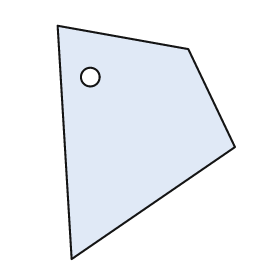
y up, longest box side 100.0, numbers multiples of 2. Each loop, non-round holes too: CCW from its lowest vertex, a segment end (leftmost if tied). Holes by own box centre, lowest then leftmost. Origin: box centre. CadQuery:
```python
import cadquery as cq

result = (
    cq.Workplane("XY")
    .moveTo(-32.0, -50.0)
    .lineTo(38.0, -2.0)
    .lineTo(18.0, 40.0)
    .lineTo(-38.0, 50.0)
    .close()
    .moveTo(-24.0, 28.0)
    .circle(4.0)
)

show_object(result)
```